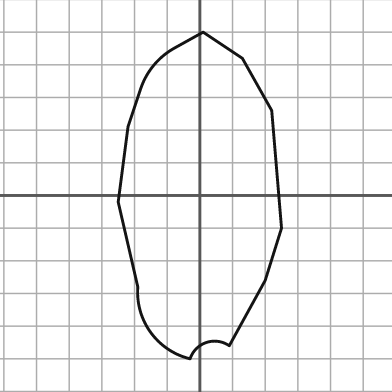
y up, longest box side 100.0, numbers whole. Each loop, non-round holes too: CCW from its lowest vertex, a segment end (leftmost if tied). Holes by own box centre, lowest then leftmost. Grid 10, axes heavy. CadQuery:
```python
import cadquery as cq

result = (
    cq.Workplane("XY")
    .moveTo(-3.0, -50.0)
    .threePointArc((2.0, -45.0), (9.0, -46.0))
    .lineTo(20.0, -26.0)
    .lineTo(25.0, -10.0)
    .lineTo(22.0, 26.0)
    .lineTo(13.0, 42.0)
    .lineTo(1.0, 50.0)
    .lineTo(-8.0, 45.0)
    .threePointArc((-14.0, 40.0), (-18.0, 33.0))
    .lineTo(-22.0, 21.0)
    .lineTo(-25.0, -2.0)
    .lineTo(-19.0, -28.0)
    .threePointArc((-15.0, -42.0), (-3.0, -50.0))
    .close()
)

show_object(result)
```